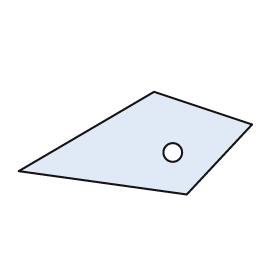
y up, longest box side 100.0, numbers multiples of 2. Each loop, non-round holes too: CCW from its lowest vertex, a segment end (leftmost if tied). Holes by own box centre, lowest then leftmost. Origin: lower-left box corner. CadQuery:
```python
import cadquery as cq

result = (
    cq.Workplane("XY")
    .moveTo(72.0, 0.0)
    .lineTo(100.0, 30.0)
    .lineTo(58.0, 44.0)
    .lineTo(0.0, 10.0)
    .close()
    .moveTo(66.0, 18.0)
    .circle(4.0)
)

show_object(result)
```